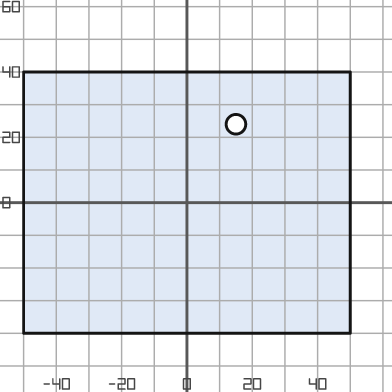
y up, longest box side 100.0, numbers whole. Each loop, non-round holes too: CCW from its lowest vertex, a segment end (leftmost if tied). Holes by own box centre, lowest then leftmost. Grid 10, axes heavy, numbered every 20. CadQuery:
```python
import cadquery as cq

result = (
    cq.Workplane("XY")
    .moveTo(-50.0, -40.0)
    .lineTo(50.0, -40.0)
    .lineTo(50.0, 40.0)
    .lineTo(-50.0, 40.0)
    .close()
    .moveTo(15.0, 24.0)
    .circle(3.0)
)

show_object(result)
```